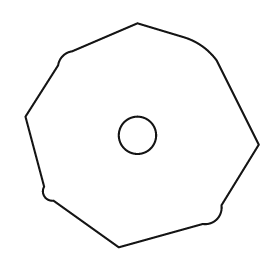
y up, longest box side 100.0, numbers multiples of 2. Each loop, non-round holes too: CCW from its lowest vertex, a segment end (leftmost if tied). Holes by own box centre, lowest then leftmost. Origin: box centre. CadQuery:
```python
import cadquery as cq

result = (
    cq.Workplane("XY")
    .moveTo(-10.0, -48.0)
    .lineTo(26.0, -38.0)
    .threePointArc((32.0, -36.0), (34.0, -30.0))
    .lineTo(50.0, -4.0)
    .lineTo(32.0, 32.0)
    .threePointArc((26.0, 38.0), (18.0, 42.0))
    .lineTo(-2.0, 48.0)
    .lineTo(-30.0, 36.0)
    .threePointArc((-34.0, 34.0), (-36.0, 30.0))
    .lineTo(-50.0, 8.0)
    .lineTo(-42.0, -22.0)
    .threePointArc((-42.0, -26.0), (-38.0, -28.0))
    .close()
    .moveTo(-2.0, 0.0)
    .circle(8.0)
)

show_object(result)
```